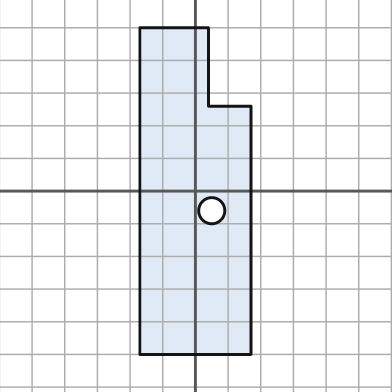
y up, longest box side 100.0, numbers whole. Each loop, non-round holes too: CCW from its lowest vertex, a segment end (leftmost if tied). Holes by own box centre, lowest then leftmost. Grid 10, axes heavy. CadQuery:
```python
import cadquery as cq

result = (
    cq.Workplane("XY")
    .moveTo(-17.0, -50.0)
    .lineTo(17.0, -50.0)
    .lineTo(17.0, 26.0)
    .lineTo(4.0, 26.0)
    .lineTo(4.0, 50.0)
    .lineTo(-17.0, 50.0)
    .close()
    .moveTo(5.0, -6.0)
    .circle(4.0)
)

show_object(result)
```